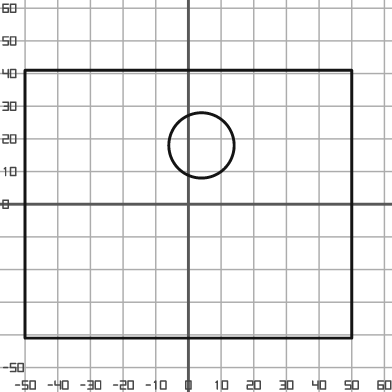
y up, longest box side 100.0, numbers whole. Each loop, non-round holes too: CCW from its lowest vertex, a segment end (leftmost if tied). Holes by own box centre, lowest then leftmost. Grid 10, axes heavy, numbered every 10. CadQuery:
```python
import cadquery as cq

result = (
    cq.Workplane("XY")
    .moveTo(-50.0, -41.0)
    .lineTo(50.0, -41.0)
    .lineTo(50.0, 41.0)
    .lineTo(-50.0, 41.0)
    .close()
    .moveTo(4.0, 18.0)
    .circle(10.0)
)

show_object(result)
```